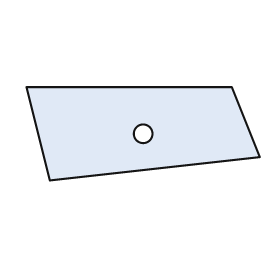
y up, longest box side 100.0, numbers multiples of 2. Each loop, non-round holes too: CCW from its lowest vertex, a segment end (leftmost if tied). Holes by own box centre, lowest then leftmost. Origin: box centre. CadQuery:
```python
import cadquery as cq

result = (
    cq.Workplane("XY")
    .moveTo(-40.0, -20.0)
    .lineTo(50.0, -10.0)
    .lineTo(38.0, 20.0)
    .lineTo(-50.0, 20.0)
    .close()
    .moveTo(0.0, 0.0)
    .circle(4.0)
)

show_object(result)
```